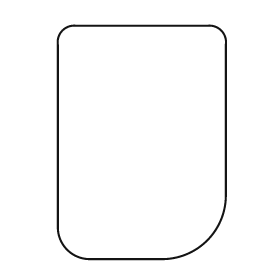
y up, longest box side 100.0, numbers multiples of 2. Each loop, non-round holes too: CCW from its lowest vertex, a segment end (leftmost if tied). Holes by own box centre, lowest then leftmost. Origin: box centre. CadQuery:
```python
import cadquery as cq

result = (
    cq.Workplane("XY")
    .moveTo(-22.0, -50.0)
    .lineTo(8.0, -50.0)
    .threePointArc((28.0, -42.0), (36.0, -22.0))
    .lineTo(36.0, 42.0)
    .threePointArc((34.0, 48.0), (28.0, 50.0))
    .lineTo(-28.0, 50.0)
    .threePointArc((-34.0, 48.0), (-36.0, 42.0))
    .lineTo(-36.0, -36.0)
    .threePointArc((-32.0, -46.0), (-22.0, -50.0))
    .close()
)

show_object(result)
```